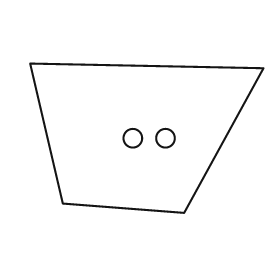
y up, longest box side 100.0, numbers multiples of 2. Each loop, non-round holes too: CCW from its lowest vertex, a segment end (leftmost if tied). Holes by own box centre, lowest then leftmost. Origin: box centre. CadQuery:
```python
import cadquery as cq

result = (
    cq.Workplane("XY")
    .moveTo(16.0, -32.0)
    .lineTo(50.0, 30.0)
    .lineTo(-50.0, 32.0)
    .lineTo(-36.0, -28.0)
    .close()
    .moveTo(-6.0, 0.0)
    .circle(4.0)
    .moveTo(8.0, 0.0)
    .circle(4.0)
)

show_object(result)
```